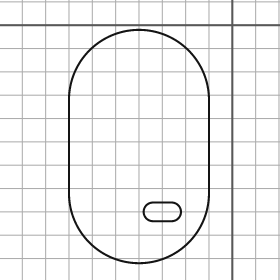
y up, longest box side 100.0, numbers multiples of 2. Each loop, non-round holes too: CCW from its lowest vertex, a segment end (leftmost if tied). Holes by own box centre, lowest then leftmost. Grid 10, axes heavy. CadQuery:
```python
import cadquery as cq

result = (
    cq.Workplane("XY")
    .moveTo(-70.0, -72.0)
    .threePointArc((-40.0, -102.0), (-10.0, -72.0))
    .lineTo(-10.0, -32.0)
    .threePointArc((-40.0, -2.0), (-70.0, -32.0))
    .close()
    .moveTo(-34.0, -84.0)
    .lineTo(-26.0, -84.0)
    .threePointArc((-22.0, -80.0), (-26.0, -76.0))
    .lineTo(-34.0, -76.0)
    .threePointArc((-38.0, -80.0), (-34.0, -84.0))
    .close()
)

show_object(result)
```